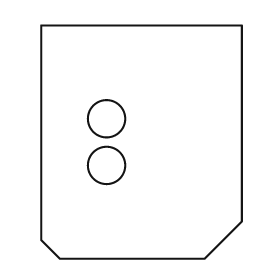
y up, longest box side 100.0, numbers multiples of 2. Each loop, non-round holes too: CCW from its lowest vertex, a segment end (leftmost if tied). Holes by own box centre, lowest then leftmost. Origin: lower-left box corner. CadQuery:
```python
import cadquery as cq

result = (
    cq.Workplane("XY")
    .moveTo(8.0, 0.0)
    .lineTo(70.0, 0.0)
    .lineTo(86.0, 16.0)
    .lineTo(86.0, 100.0)
    .lineTo(0.0, 100.0)
    .lineTo(0.0, 8.0)
    .close()
    .moveTo(28.0, 40.0)
    .circle(8.0)
    .moveTo(28.0, 60.0)
    .circle(8.0)
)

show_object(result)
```